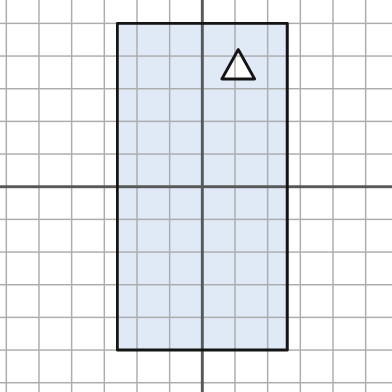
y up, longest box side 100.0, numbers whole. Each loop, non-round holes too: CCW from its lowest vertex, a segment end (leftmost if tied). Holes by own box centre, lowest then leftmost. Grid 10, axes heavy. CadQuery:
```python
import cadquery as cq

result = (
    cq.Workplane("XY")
    .moveTo(-26.0, -50.0)
    .lineTo(26.0, -50.0)
    .lineTo(26.0, 50.0)
    .lineTo(-26.0, 50.0)
    .close()
    .moveTo(6.0, 33.0)
    .lineTo(16.0, 33.0)
    .lineTo(11.0, 42.0)
    .close()
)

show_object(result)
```